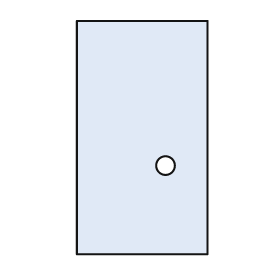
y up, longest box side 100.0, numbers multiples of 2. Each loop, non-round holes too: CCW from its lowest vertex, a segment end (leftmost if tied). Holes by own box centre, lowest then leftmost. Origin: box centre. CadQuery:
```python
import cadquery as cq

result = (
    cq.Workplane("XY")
    .moveTo(-28.0, -50.0)
    .lineTo(28.0, -50.0)
    .lineTo(28.0, 50.0)
    .lineTo(-28.0, 50.0)
    .close()
    .moveTo(10.0, -12.0)
    .circle(4.0)
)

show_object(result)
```